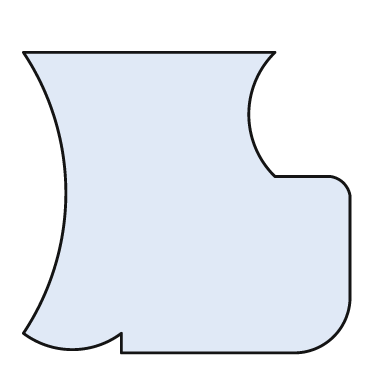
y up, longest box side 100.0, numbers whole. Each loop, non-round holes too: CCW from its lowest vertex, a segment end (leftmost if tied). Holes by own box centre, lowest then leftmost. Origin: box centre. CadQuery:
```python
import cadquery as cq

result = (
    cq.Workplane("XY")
    .moveTo(-20.0, -46.0)
    .lineTo(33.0, -46.0)
    .threePointArc((45.0, -41.0), (50.0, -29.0))
    .lineTo(50.0, 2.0)
    .threePointArc((48.0, 6.0), (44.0, 8.0))
    .lineTo(27.0, 8.0)
    .threePointArc((19.0, 27.0), (27.0, 46.0))
    .lineTo(-50.0, 46.0)
    .threePointArc((-37.0, 3.0), (-50.0, -40.0))
    .threePointArc((-35.0, -45.0), (-20.0, -40.0))
    .close()
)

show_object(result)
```